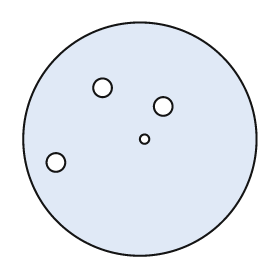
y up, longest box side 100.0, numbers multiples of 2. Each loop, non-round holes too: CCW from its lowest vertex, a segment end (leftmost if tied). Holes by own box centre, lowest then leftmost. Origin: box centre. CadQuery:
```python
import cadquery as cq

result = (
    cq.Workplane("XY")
    .moveTo(0.0, 0.0)
    .circle(50.0)
    .moveTo(-36.0, -10.0)
    .circle(4.0)
    .moveTo(2.0, 0.0)
    .circle(2.0)
    .moveTo(10.0, 14.0)
    .circle(4.0)
    .moveTo(-16.0, 22.0)
    .circle(4.0)
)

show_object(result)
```